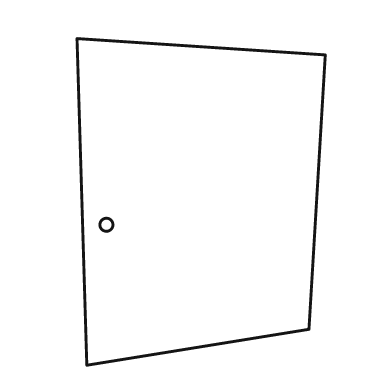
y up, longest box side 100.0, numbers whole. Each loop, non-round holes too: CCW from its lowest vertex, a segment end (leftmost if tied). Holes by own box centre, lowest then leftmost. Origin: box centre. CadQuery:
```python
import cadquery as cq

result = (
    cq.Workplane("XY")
    .moveTo(-35.0, -50.0)
    .lineTo(33.0, -39.0)
    .lineTo(38.0, 45.0)
    .lineTo(-38.0, 50.0)
    .close()
    .moveTo(-29.0, -7.0)
    .circle(2.0)
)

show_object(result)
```